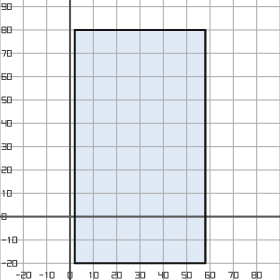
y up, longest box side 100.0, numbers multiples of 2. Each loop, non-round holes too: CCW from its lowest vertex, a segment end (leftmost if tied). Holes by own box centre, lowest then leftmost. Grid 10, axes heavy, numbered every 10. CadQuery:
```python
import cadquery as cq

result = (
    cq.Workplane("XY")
    .moveTo(2.0, -20.0)
    .lineTo(58.0, -20.0)
    .lineTo(58.0, 80.0)
    .lineTo(2.0, 80.0)
    .close()
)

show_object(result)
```